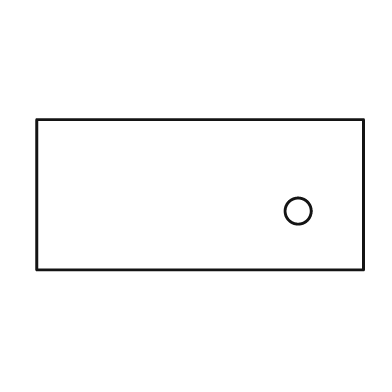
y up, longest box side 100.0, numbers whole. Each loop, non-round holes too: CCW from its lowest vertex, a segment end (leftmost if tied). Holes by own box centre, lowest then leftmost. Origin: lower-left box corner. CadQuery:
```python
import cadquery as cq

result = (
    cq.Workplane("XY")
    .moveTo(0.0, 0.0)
    .lineTo(100.0, 0.0)
    .lineTo(100.0, 46.0)
    .lineTo(0.0, 46.0)
    .close()
    .moveTo(80.0, 18.0)
    .circle(4.0)
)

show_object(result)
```